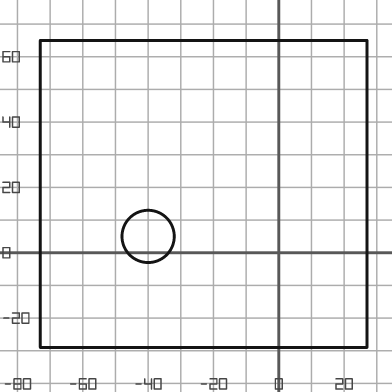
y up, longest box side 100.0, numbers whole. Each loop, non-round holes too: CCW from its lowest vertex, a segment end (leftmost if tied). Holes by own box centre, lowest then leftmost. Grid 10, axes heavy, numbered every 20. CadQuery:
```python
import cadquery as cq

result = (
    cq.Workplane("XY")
    .moveTo(-73.0, -29.0)
    .lineTo(27.0, -29.0)
    .lineTo(27.0, 65.0)
    .lineTo(-73.0, 65.0)
    .close()
    .moveTo(-40.0, 5.0)
    .circle(8.0)
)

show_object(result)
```